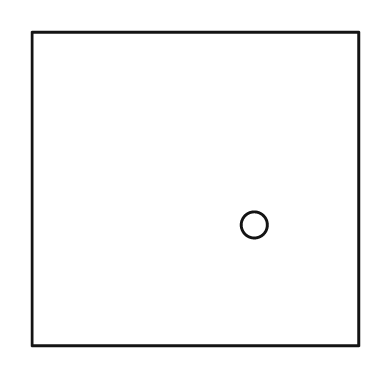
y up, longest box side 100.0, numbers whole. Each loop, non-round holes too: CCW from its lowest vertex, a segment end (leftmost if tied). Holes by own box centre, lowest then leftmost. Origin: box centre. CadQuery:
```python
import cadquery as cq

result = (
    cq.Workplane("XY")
    .moveTo(-50.0, -48.0)
    .lineTo(50.0, -48.0)
    .lineTo(50.0, 48.0)
    .lineTo(-50.0, 48.0)
    .close()
    .moveTo(18.0, -11.0)
    .circle(4.0)
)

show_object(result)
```